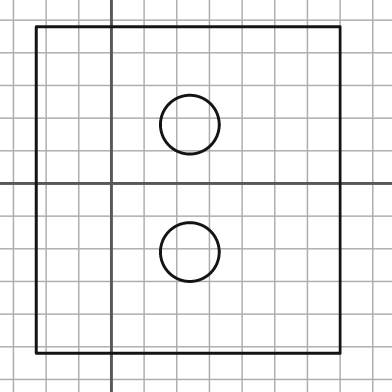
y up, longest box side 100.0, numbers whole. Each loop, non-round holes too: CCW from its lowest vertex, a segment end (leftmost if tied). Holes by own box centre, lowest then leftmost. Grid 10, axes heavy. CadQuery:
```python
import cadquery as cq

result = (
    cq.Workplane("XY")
    .moveTo(-23.0, -52.0)
    .lineTo(70.0, -52.0)
    .lineTo(70.0, 48.0)
    .lineTo(-23.0, 48.0)
    .close()
    .moveTo(24.0, -21.0)
    .circle(9.0)
    .moveTo(24.0, 18.0)
    .circle(9.0)
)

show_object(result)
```